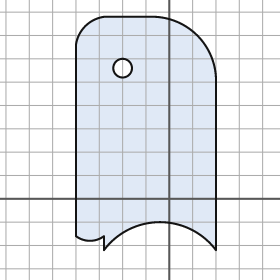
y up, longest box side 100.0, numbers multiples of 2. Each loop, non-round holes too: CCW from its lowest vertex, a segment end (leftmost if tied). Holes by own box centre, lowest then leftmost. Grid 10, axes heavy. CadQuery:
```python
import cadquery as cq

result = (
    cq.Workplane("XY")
    .moveTo(-28.0, -22.0)
    .threePointArc((-4.0, -10.0), (20.0, -22.0))
    .lineTo(20.0, 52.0)
    .threePointArc((12.0, 70.0), (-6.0, 78.0))
    .lineTo(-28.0, 78.0)
    .threePointArc((-36.0, 74.0), (-40.0, 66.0))
    .lineTo(-40.0, -16.0)
    .threePointArc((-34.0, -18.0), (-28.0, -16.0))
    .close()
    .moveTo(-20.0, 56.0)
    .circle(4.0)
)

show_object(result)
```